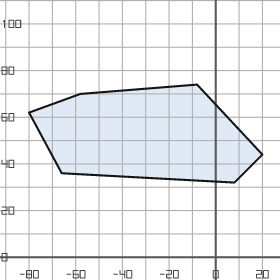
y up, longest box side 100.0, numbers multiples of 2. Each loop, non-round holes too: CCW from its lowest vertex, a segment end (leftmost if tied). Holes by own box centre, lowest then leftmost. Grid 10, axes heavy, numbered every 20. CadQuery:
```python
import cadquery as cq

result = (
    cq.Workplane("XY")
    .moveTo(8.0, 32.0)
    .lineTo(20.0, 44.0)
    .lineTo(-8.0, 74.0)
    .lineTo(-58.0, 70.0)
    .lineTo(-80.0, 62.0)
    .lineTo(-66.0, 36.0)
    .close()
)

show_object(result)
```